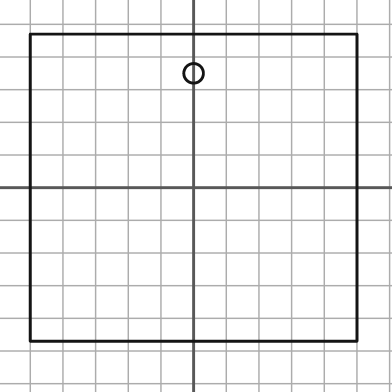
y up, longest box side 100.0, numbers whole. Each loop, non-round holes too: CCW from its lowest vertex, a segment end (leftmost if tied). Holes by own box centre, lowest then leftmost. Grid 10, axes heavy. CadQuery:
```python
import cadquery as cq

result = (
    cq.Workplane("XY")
    .moveTo(-50.0, -47.0)
    .lineTo(50.0, -47.0)
    .lineTo(50.0, 47.0)
    .lineTo(-50.0, 47.0)
    .close()
    .moveTo(0.0, 35.0)
    .circle(3.0)
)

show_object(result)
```